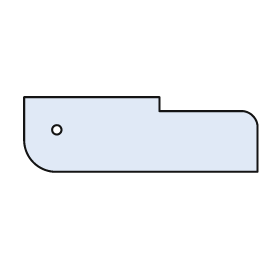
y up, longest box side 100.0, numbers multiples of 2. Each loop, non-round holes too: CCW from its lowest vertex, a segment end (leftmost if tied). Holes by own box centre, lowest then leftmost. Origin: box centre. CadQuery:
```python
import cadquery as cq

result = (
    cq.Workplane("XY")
    .moveTo(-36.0, -16.0)
    .lineTo(50.0, -16.0)
    .lineTo(50.0, 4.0)
    .threePointArc((48.0, 8.0), (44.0, 10.0))
    .lineTo(8.0, 10.0)
    .lineTo(8.0, 16.0)
    .lineTo(-50.0, 16.0)
    .lineTo(-50.0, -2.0)
    .threePointArc((-46.0, -12.0), (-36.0, -16.0))
    .close()
    .moveTo(-36.0, 2.0)
    .circle(2.0)
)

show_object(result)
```